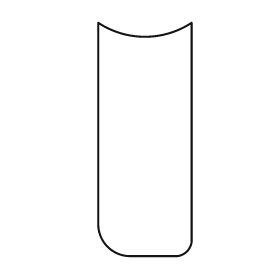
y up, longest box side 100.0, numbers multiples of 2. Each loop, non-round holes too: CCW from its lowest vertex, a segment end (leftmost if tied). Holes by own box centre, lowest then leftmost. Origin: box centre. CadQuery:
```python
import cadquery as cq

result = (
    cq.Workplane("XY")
    .moveTo(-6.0, -50.0)
    .lineTo(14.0, -50.0)
    .threePointArc((18.0, -48.0), (20.0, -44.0))
    .lineTo(20.0, 50.0)
    .threePointArc((0.0, 44.0), (-20.0, 50.0))
    .lineTo(-20.0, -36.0)
    .threePointArc((-16.0, -46.0), (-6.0, -50.0))
    .close()
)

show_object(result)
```